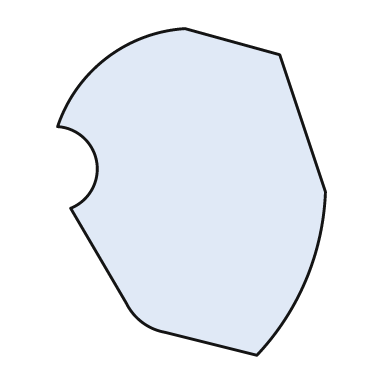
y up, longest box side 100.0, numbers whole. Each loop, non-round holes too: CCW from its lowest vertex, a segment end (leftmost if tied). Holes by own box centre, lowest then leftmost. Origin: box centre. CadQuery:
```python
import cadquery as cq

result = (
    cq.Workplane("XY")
    .moveTo(20.0, -50.0)
    .threePointArc((35.0, -27.0), (41.0, 0.0))
    .lineTo(27.0, 42.0)
    .lineTo(-2.0, 50.0)
    .threePointArc((-26.0, 41.0), (-41.0, 20.0))
    .threePointArc((-29.0, 9.0), (-37.0, -5.0))
    .lineTo(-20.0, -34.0)
    .threePointArc((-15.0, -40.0), (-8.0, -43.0))
    .close()
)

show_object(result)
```